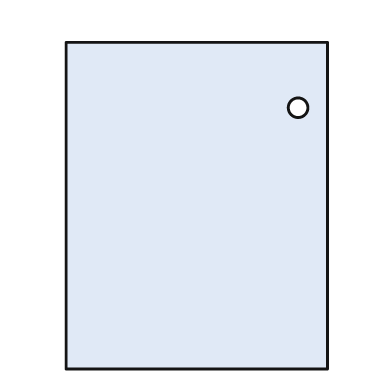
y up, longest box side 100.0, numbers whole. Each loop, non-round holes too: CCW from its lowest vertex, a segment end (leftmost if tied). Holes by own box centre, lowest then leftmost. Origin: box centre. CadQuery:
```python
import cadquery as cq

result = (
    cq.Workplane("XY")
    .moveTo(-40.0, -50.0)
    .lineTo(40.0, -50.0)
    .lineTo(40.0, 50.0)
    .lineTo(-40.0, 50.0)
    .close()
    .moveTo(31.0, 30.0)
    .circle(3.0)
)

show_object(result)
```